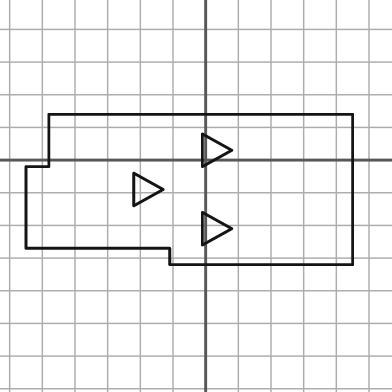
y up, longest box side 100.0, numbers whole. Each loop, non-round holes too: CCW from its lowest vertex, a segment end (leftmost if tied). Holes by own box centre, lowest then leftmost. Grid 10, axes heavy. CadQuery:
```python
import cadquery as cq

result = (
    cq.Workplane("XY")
    .moveTo(-11.0, -32.0)
    .lineTo(45.0, -32.0)
    .lineTo(45.0, 14.0)
    .lineTo(-48.0, 14.0)
    .lineTo(-48.0, -2.0)
    .lineTo(-55.0, -2.0)
    .lineTo(-55.0, -27.0)
    .lineTo(-11.0, -27.0)
    .close()
    .moveTo(-1.0, -26.0)
    .lineTo(8.0, -21.0)
    .lineTo(-1.0, -16.0)
    .close()
    .moveTo(-22.0, -14.0)
    .lineTo(-13.0, -9.0)
    .lineTo(-22.0, -4.0)
    .close()
    .moveTo(-1.0, -2.0)
    .lineTo(8.0, 3.0)
    .lineTo(-1.0, 8.0)
    .close()
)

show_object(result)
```